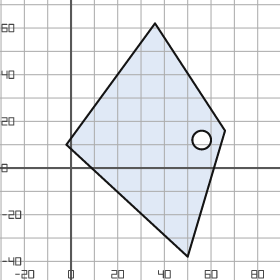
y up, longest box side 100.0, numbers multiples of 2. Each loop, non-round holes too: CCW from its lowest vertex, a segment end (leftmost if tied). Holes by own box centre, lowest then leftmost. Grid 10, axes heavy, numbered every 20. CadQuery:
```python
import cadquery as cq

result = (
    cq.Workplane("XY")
    .moveTo(50.0, -38.0)
    .lineTo(66.0, 16.0)
    .lineTo(36.0, 62.0)
    .lineTo(-2.0, 10.0)
    .close()
    .moveTo(56.0, 12.0)
    .circle(4.0)
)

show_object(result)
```